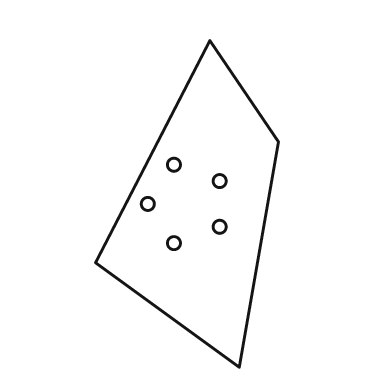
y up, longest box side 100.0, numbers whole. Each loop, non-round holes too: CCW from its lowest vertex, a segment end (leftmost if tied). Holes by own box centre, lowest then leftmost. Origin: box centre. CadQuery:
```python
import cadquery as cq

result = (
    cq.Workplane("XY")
    .moveTo(16.0, -50.0)
    .lineTo(28.0, 19.0)
    .lineTo(7.0, 50.0)
    .lineTo(-28.0, -18.0)
    .close()
    .moveTo(-4.0, -12.0)
    .circle(2.0)
    .moveTo(10.0, -7.0)
    .circle(2.0)
    .moveTo(-12.0, 0.0)
    .circle(2.0)
    .moveTo(10.0, 7.0)
    .circle(2.0)
    .moveTo(-4.0, 12.0)
    .circle(2.0)
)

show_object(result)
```